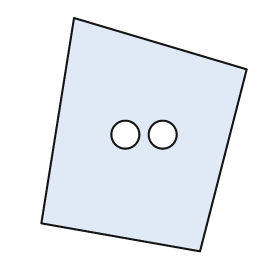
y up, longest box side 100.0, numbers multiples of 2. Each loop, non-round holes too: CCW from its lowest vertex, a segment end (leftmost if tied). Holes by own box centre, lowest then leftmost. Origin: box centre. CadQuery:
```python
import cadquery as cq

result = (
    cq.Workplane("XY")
    .moveTo(24.0, -50.0)
    .lineTo(44.0, 28.0)
    .lineTo(-30.0, 50.0)
    .lineTo(-44.0, -38.0)
    .close()
    .moveTo(-8.0, 0.0)
    .circle(6.0)
    .moveTo(8.0, 0.0)
    .circle(6.0)
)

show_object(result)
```